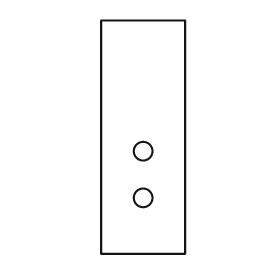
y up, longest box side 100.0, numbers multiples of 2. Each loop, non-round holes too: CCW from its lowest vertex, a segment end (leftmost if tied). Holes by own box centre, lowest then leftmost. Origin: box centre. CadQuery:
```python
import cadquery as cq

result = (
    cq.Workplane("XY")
    .moveTo(-18.0, -50.0)
    .lineTo(18.0, -50.0)
    .lineTo(18.0, 50.0)
    .lineTo(-18.0, 50.0)
    .close()
    .moveTo(0.0, -26.0)
    .circle(4.0)
    .moveTo(0.0, -6.0)
    .circle(4.0)
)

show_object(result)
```